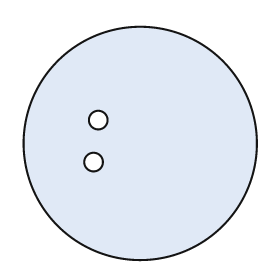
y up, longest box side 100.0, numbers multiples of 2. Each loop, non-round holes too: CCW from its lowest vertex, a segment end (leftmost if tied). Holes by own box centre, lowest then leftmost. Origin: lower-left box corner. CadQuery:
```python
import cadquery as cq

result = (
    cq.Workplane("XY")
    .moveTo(50.0, 50.0)
    .circle(50.0)
    .moveTo(30.0, 42.0)
    .circle(4.0)
    .moveTo(32.0, 60.0)
    .circle(4.0)
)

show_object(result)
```